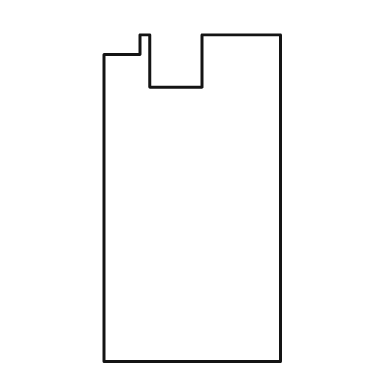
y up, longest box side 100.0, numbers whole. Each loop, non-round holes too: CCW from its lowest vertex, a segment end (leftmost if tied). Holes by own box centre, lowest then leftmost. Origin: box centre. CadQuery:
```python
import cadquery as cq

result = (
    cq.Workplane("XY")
    .moveTo(-27.0, -50.0)
    .lineTo(27.0, -50.0)
    .lineTo(27.0, 50.0)
    .lineTo(3.0, 50.0)
    .lineTo(3.0, 34.0)
    .lineTo(-13.0, 34.0)
    .lineTo(-13.0, 50.0)
    .lineTo(-16.0, 50.0)
    .lineTo(-16.0, 44.0)
    .lineTo(-27.0, 44.0)
    .close()
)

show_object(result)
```